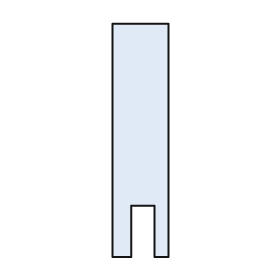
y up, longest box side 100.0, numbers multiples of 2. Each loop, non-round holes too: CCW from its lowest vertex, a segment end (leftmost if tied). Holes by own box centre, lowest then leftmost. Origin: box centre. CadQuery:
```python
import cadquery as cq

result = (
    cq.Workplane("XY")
    .moveTo(-12.0, -50.0)
    .lineTo(-4.0, -50.0)
    .lineTo(-4.0, -28.0)
    .lineTo(6.0, -28.0)
    .lineTo(6.0, -50.0)
    .lineTo(12.0, -50.0)
    .lineTo(12.0, 50.0)
    .lineTo(-12.0, 50.0)
    .close()
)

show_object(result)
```